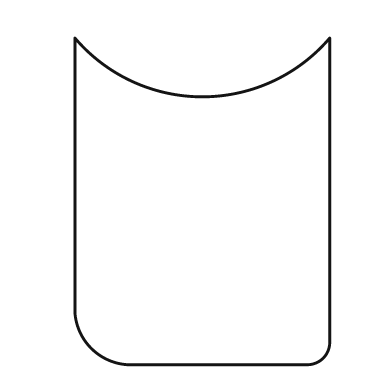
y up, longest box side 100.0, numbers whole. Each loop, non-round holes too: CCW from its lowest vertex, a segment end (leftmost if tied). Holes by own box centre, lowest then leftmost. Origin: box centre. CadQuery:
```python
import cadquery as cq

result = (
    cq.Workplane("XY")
    .moveTo(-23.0, -50.0)
    .lineTo(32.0, -50.0)
    .threePointArc((37.0, -48.0), (39.0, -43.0))
    .lineTo(39.0, 50.0)
    .threePointArc((0.0, 32.0), (-39.0, 50.0))
    .lineTo(-39.0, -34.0)
    .threePointArc((-34.0, -45.0), (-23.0, -50.0))
    .close()
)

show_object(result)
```